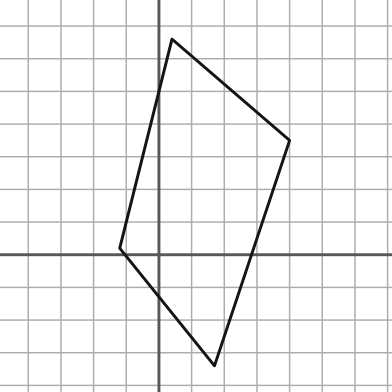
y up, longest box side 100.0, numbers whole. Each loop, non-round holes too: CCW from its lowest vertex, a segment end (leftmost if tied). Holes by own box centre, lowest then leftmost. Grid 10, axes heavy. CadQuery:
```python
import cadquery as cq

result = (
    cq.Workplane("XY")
    .moveTo(17.0, -34.0)
    .lineTo(40.0, 35.0)
    .lineTo(4.0, 66.0)
    .lineTo(-12.0, 2.0)
    .close()
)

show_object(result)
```